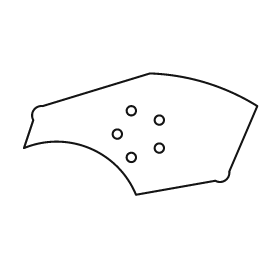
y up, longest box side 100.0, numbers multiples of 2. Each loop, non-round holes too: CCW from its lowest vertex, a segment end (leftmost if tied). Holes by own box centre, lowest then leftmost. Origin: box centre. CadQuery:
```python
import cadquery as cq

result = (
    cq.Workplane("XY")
    .moveTo(-2.0, -26.0)
    .lineTo(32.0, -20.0)
    .threePointArc((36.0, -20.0), (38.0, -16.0))
    .lineTo(50.0, 12.0)
    .threePointArc((28.0, 22.0), (4.0, 26.0))
    .lineTo(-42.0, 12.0)
    .threePointArc((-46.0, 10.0), (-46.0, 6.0))
    .lineTo(-50.0, -6.0)
    .threePointArc((-22.0, -6.0), (-2.0, -26.0))
    .close()
    .moveTo(-4.0, -10.0)
    .circle(2.0)
    .moveTo(8.0, -6.0)
    .circle(2.0)
    .moveTo(-10.0, 0.0)
    .circle(2.0)
    .moveTo(8.0, 6.0)
    .circle(2.0)
    .moveTo(-4.0, 10.0)
    .circle(2.0)
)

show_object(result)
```